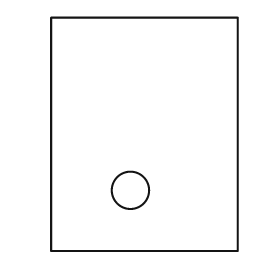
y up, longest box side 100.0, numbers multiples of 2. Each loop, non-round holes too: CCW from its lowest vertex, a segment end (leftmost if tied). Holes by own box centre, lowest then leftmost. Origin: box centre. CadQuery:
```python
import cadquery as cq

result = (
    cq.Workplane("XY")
    .moveTo(-40.0, -50.0)
    .lineTo(40.0, -50.0)
    .lineTo(40.0, 50.0)
    .lineTo(-40.0, 50.0)
    .close()
    .moveTo(-6.0, -24.0)
    .circle(8.0)
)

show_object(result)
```